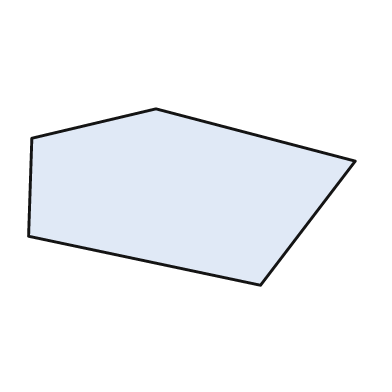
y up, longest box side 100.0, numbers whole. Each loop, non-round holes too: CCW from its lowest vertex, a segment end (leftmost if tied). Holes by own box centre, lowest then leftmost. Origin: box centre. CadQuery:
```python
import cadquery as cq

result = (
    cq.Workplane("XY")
    .moveTo(21.0, -27.0)
    .lineTo(50.0, 11.0)
    .lineTo(-11.0, 27.0)
    .lineTo(-49.0, 18.0)
    .lineTo(-50.0, -12.0)
    .close()
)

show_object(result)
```